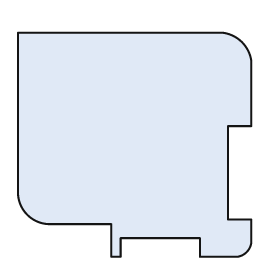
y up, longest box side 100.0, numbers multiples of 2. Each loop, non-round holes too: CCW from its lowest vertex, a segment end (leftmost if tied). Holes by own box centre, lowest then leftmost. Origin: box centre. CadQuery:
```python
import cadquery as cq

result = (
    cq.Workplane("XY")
    .moveTo(-10.0, -48.0)
    .lineTo(-6.0, -48.0)
    .lineTo(-6.0, -40.0)
    .lineTo(28.0, -40.0)
    .lineTo(28.0, -48.0)
    .lineTo(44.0, -48.0)
    .threePointArc((48.0, -46.0), (50.0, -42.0))
    .lineTo(50.0, -32.0)
    .lineTo(40.0, -32.0)
    .lineTo(40.0, 8.0)
    .lineTo(50.0, 8.0)
    .lineTo(50.0, 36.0)
    .threePointArc((46.0, 44.0), (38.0, 48.0))
    .lineTo(-50.0, 48.0)
    .lineTo(-50.0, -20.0)
    .threePointArc((-46.0, -30.0), (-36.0, -34.0))
    .lineTo(-10.0, -34.0)
    .close()
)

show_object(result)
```